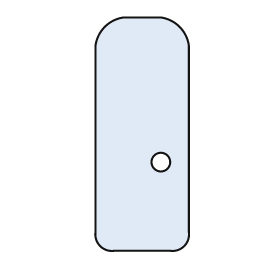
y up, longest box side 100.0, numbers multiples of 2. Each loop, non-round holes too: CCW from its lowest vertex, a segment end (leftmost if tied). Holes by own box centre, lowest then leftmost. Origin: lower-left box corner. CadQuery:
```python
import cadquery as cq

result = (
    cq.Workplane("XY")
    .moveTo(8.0, 0.0)
    .lineTo(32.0, 0.0)
    .threePointArc((38.0, 2.0), (40.0, 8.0))
    .lineTo(40.0, 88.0)
    .threePointArc((36.0, 96.0), (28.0, 100.0))
    .lineTo(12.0, 100.0)
    .threePointArc((4.0, 96.0), (0.0, 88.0))
    .lineTo(0.0, 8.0)
    .threePointArc((2.0, 2.0), (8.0, 0.0))
    .close()
    .moveTo(28.0, 38.0)
    .circle(4.0)
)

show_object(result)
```